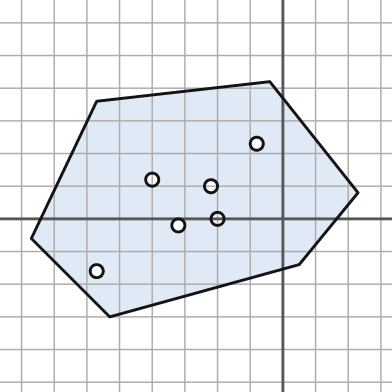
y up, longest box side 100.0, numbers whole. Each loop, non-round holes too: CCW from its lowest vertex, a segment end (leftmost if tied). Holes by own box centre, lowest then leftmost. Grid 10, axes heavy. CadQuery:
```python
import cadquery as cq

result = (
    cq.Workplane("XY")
    .moveTo(-53.0, -30.0)
    .lineTo(5.0, -14.0)
    .lineTo(23.0, 8.0)
    .lineTo(-4.0, 42.0)
    .lineTo(-57.0, 36.0)
    .lineTo(-77.0, -6.0)
    .close()
    .moveTo(-57.0, -16.0)
    .circle(2.0)
    .moveTo(-32.0, -2.0)
    .circle(2.0)
    .moveTo(-20.0, 0.0)
    .circle(2.0)
    .moveTo(-22.0, 10.0)
    .circle(2.0)
    .moveTo(-40.0, 12.0)
    .circle(2.0)
    .moveTo(-8.0, 23.0)
    .circle(2.0)
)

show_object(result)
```